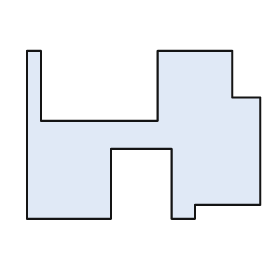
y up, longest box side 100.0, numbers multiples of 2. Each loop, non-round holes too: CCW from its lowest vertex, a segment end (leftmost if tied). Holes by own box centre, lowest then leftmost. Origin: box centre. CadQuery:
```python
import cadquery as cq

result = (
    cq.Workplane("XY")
    .moveTo(-50.0, -36.0)
    .lineTo(-14.0, -36.0)
    .lineTo(-14.0, -6.0)
    .lineTo(12.0, -6.0)
    .lineTo(12.0, -36.0)
    .lineTo(22.0, -36.0)
    .lineTo(22.0, -30.0)
    .lineTo(50.0, -30.0)
    .lineTo(50.0, 16.0)
    .lineTo(38.0, 16.0)
    .lineTo(38.0, 36.0)
    .lineTo(6.0, 36.0)
    .lineTo(6.0, 6.0)
    .lineTo(-44.0, 6.0)
    .lineTo(-44.0, 36.0)
    .lineTo(-50.0, 36.0)
    .close()
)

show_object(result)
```